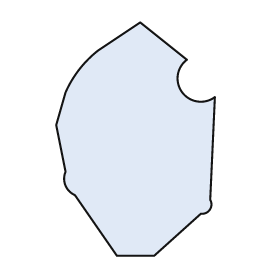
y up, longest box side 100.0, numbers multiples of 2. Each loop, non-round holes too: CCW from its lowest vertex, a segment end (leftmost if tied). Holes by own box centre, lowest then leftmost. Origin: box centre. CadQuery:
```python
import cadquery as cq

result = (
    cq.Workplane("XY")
    .moveTo(-8.0, -50.0)
    .lineTo(8.0, -50.0)
    .lineTo(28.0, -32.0)
    .threePointArc((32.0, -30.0), (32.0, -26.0))
    .lineTo(34.0, 18.0)
    .threePointArc((20.0, 20.0), (22.0, 34.0))
    .lineTo(2.0, 50.0)
    .lineTo(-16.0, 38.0)
    .threePointArc((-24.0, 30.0), (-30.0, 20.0))
    .lineTo(-34.0, 6.0)
    .lineTo(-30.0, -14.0)
    .threePointArc((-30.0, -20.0), (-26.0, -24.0))
    .close()
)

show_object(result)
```